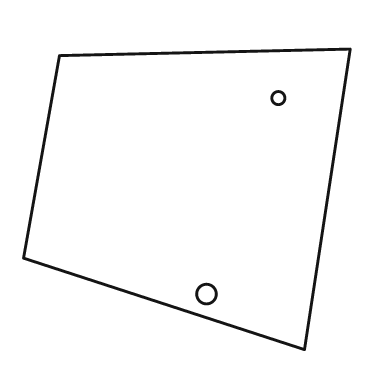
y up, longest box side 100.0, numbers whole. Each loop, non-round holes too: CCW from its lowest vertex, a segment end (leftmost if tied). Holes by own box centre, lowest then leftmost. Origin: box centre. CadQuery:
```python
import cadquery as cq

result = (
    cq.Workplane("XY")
    .moveTo(36.0, -46.0)
    .lineTo(50.0, 46.0)
    .lineTo(-39.0, 44.0)
    .lineTo(-50.0, -18.0)
    .close()
    .moveTo(6.0, -29.0)
    .circle(3.0)
    .moveTo(28.0, 31.0)
    .circle(2.0)
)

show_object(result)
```